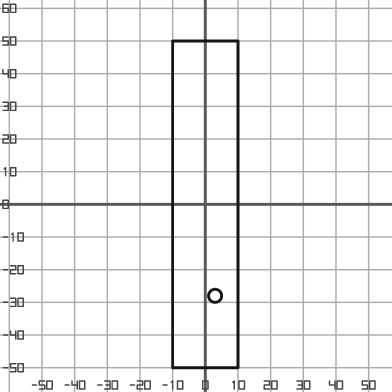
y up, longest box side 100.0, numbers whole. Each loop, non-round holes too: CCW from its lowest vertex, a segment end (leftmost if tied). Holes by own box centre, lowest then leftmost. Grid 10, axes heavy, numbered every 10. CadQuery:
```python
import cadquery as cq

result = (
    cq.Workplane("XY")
    .moveTo(-10.0, -50.0)
    .lineTo(10.0, -50.0)
    .lineTo(10.0, 50.0)
    .lineTo(-10.0, 50.0)
    .close()
    .moveTo(3.0, -28.0)
    .circle(2.0)
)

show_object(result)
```